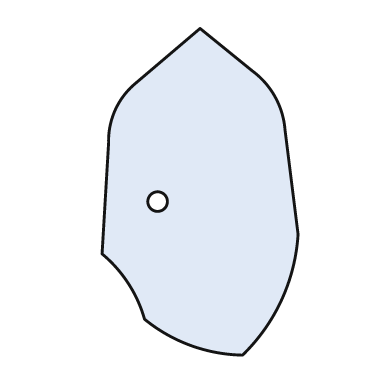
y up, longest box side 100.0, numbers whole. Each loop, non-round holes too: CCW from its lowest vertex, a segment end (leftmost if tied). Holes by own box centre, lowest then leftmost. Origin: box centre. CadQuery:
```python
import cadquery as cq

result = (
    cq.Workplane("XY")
    .moveTo(13.0, -50.0)
    .threePointArc((25.0, -33.0), (30.0, -13.0))
    .lineTo(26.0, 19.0)
    .threePointArc((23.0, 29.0), (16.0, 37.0))
    .lineTo(0.0, 50.0)
    .lineTo(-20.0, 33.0)
    .threePointArc((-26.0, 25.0), (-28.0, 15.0))
    .lineTo(-30.0, -19.0)
    .threePointArc((-22.0, -28.0), (-17.0, -39.0))
    .threePointArc((-3.0, -47.0), (13.0, -50.0))
    .close()
    .moveTo(-13.0, -3.0)
    .circle(3.0)
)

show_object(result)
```